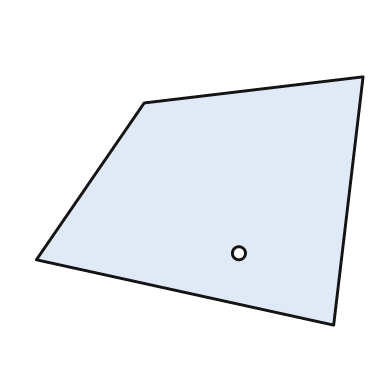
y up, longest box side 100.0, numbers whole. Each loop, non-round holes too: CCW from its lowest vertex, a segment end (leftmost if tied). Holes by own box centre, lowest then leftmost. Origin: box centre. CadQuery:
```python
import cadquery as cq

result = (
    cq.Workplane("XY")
    .moveTo(41.0, -38.0)
    .lineTo(50.0, 38.0)
    .lineTo(-17.0, 30.0)
    .lineTo(-50.0, -18.0)
    .close()
    .moveTo(12.0, -16.0)
    .circle(2.0)
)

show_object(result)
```